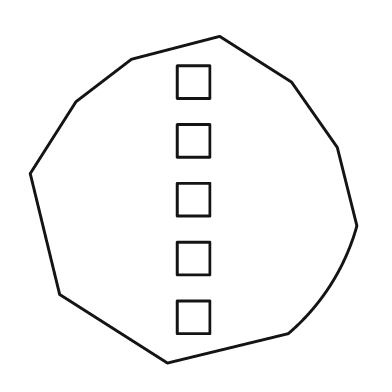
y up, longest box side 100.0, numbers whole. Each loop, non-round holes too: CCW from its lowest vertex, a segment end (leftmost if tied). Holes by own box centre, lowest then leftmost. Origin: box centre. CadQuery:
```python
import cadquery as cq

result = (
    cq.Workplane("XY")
    .moveTo(-8.0, -50.0)
    .lineTo(29.0, -41.0)
    .threePointArc((42.0, -26.0), (50.0, -8.0))
    .lineTo(44.0, 16.0)
    .lineTo(30.0, 36.0)
    .lineTo(8.0, 50.0)
    .lineTo(-19.0, 43.0)
    .lineTo(-36.0, 30.0)
    .lineTo(-50.0, 8.0)
    .lineTo(-41.0, -29.0)
    .close()
    .moveTo(-5.0, -41.0)
    .lineTo(5.0, -41.0)
    .lineTo(5.0, -31.0)
    .lineTo(-5.0, -31.0)
    .close()
    .moveTo(-5.0, -23.0)
    .lineTo(5.0, -23.0)
    .lineTo(5.0, -13.0)
    .lineTo(-5.0, -13.0)
    .close()
    .moveTo(-5.0, -5.0)
    .lineTo(5.0, -5.0)
    .lineTo(5.0, 5.0)
    .lineTo(-5.0, 5.0)
    .close()
    .moveTo(-5.0, 13.0)
    .lineTo(5.0, 13.0)
    .lineTo(5.0, 23.0)
    .lineTo(-5.0, 23.0)
    .close()
    .moveTo(-5.0, 31.0)
    .lineTo(5.0, 31.0)
    .lineTo(5.0, 41.0)
    .lineTo(-5.0, 41.0)
    .close()
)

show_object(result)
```